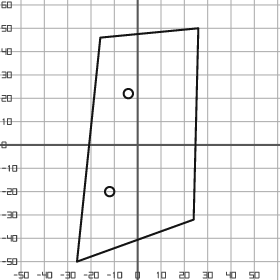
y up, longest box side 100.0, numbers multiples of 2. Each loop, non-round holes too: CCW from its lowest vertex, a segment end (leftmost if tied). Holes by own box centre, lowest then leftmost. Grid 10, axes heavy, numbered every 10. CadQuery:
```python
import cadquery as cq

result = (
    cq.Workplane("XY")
    .moveTo(-26.0, -50.0)
    .lineTo(24.0, -32.0)
    .lineTo(26.0, 50.0)
    .lineTo(-16.0, 46.0)
    .close()
    .moveTo(-12.0, -20.0)
    .circle(2.0)
    .moveTo(-4.0, 22.0)
    .circle(2.0)
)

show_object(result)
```